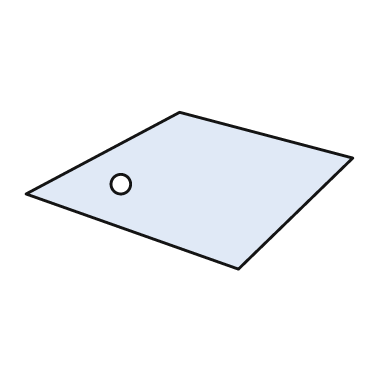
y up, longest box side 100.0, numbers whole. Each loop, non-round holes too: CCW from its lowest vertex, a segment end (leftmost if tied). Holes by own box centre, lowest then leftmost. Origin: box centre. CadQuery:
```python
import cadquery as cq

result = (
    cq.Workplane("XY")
    .moveTo(15.0, -24.0)
    .lineTo(50.0, 10.0)
    .lineTo(-3.0, 24.0)
    .lineTo(-50.0, -1.0)
    .close()
    .moveTo(-21.0, 2.0)
    .circle(3.0)
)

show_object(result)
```